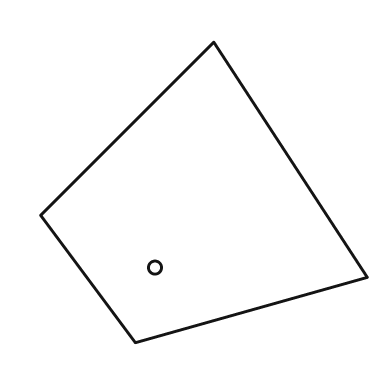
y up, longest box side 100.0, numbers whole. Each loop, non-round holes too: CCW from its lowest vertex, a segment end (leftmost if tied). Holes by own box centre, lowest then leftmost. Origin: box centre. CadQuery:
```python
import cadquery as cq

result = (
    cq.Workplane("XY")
    .moveTo(-21.0, -46.0)
    .lineTo(50.0, -26.0)
    .lineTo(3.0, 46.0)
    .lineTo(-50.0, -7.0)
    .close()
    .moveTo(-15.0, -23.0)
    .circle(2.0)
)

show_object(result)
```